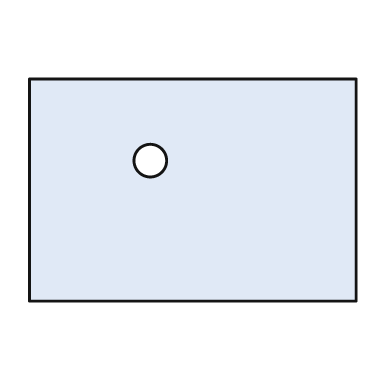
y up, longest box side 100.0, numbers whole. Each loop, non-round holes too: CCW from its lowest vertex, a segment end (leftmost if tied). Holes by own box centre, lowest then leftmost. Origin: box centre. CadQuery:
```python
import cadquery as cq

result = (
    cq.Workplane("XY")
    .moveTo(-50.0, -34.0)
    .lineTo(50.0, -34.0)
    .lineTo(50.0, 34.0)
    .lineTo(-50.0, 34.0)
    .close()
    .moveTo(-13.0, 9.0)
    .circle(5.0)
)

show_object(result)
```